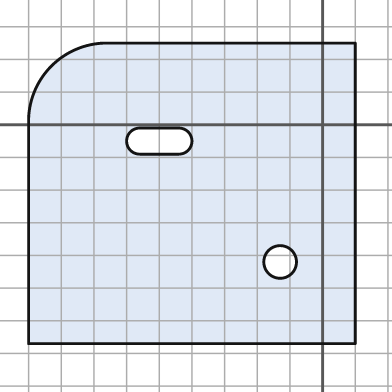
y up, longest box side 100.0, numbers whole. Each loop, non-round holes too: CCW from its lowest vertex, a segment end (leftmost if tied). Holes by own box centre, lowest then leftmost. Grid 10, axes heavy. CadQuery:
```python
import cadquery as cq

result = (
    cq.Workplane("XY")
    .moveTo(-90.0, -67.0)
    .lineTo(10.0, -67.0)
    .lineTo(10.0, 25.0)
    .lineTo(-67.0, 25.0)
    .threePointArc((-83.0, 18.0), (-90.0, 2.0))
    .close()
    .moveTo(-13.0, -42.0)
    .circle(5.0)
    .moveTo(-56.0, -9.0)
    .lineTo(-44.0, -9.0)
    .threePointArc((-40.0, -5.0), (-44.0, -1.0))
    .lineTo(-56.0, -1.0)
    .threePointArc((-60.0, -5.0), (-56.0, -9.0))
    .close()
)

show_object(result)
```